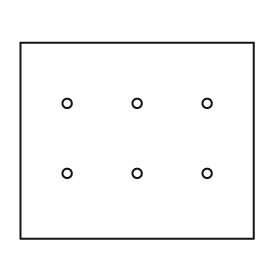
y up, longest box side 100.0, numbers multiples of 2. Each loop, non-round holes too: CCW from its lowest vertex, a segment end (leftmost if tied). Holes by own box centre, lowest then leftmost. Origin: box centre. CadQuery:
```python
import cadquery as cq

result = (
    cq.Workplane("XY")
    .moveTo(-50.0, -42.0)
    .lineTo(50.0, -42.0)
    .lineTo(50.0, 42.0)
    .lineTo(-50.0, 42.0)
    .close()
    .moveTo(-30.0, -14.0)
    .circle(2.0)
    .moveTo(0.0, -14.0)
    .circle(2.0)
    .moveTo(30.0, -14.0)
    .circle(2.0)
    .moveTo(-30.0, 16.0)
    .circle(2.0)
    .moveTo(0.0, 16.0)
    .circle(2.0)
    .moveTo(30.0, 16.0)
    .circle(2.0)
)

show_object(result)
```